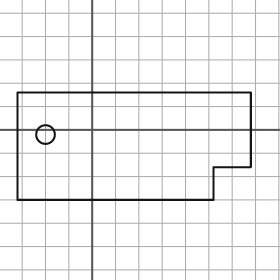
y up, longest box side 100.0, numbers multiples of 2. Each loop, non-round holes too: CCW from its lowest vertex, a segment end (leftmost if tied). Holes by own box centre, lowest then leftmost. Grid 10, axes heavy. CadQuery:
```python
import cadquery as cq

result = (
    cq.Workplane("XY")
    .moveTo(-32.0, -30.0)
    .lineTo(52.0, -30.0)
    .lineTo(52.0, -16.0)
    .lineTo(68.0, -16.0)
    .lineTo(68.0, 16.0)
    .lineTo(-32.0, 16.0)
    .close()
    .moveTo(-20.0, -2.0)
    .circle(4.0)
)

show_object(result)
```